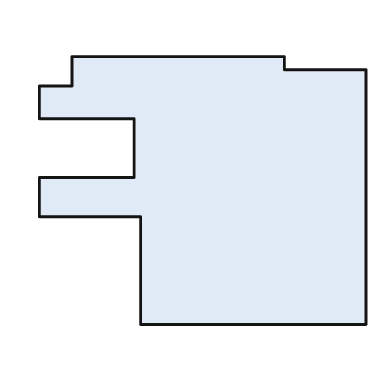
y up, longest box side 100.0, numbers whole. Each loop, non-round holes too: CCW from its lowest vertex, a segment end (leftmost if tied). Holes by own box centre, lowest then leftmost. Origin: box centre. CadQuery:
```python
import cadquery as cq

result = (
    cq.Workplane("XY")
    .moveTo(-19.0, -41.0)
    .lineTo(50.0, -41.0)
    .lineTo(50.0, 37.0)
    .lineTo(25.0, 37.0)
    .lineTo(25.0, 41.0)
    .lineTo(-40.0, 41.0)
    .lineTo(-40.0, 32.0)
    .lineTo(-50.0, 32.0)
    .lineTo(-50.0, 22.0)
    .lineTo(-21.0, 22.0)
    .lineTo(-21.0, 4.0)
    .lineTo(-50.0, 4.0)
    .lineTo(-50.0, -8.0)
    .lineTo(-19.0, -8.0)
    .close()
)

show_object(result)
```